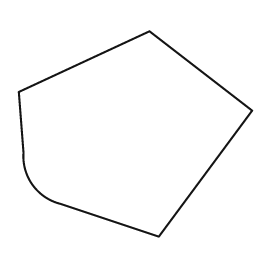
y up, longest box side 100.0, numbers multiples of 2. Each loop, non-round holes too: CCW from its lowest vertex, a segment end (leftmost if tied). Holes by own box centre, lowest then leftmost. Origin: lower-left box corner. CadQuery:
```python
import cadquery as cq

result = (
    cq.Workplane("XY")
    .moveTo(60.0, 0.0)
    .lineTo(100.0, 54.0)
    .lineTo(56.0, 88.0)
    .lineTo(0.0, 62.0)
    .lineTo(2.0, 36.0)
    .threePointArc((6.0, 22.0), (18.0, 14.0))
    .close()
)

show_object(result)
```